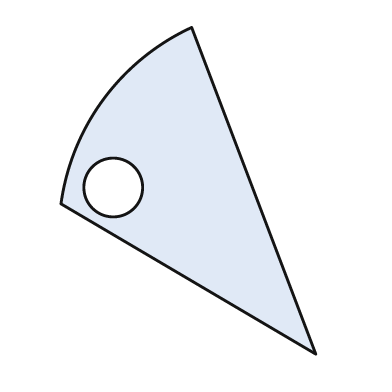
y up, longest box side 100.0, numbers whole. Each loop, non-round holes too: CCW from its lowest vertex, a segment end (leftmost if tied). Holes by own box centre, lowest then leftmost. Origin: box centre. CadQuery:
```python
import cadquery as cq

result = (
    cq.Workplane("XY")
    .moveTo(39.0, -50.0)
    .lineTo(1.0, 50.0)
    .threePointArc((-26.0, 28.0), (-39.0, -4.0))
    .close()
    .moveTo(-23.0, 1.0)
    .circle(9.0)
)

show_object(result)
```